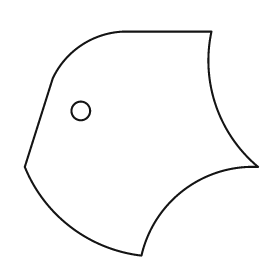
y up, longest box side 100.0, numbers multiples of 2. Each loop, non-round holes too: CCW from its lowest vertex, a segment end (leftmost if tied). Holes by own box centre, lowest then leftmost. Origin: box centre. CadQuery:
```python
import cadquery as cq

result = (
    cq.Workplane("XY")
    .moveTo(0.0, -48.0)
    .threePointArc((18.0, -20.0), (50.0, -10.0))
    .threePointArc((32.0, 16.0), (30.0, 48.0))
    .lineTo(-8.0, 48.0)
    .threePointArc((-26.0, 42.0), (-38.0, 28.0))
    .lineTo(-50.0, -10.0)
    .threePointArc((-30.0, -36.0), (0.0, -48.0))
    .close()
    .moveTo(-26.0, 14.0)
    .circle(4.0)
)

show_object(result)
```